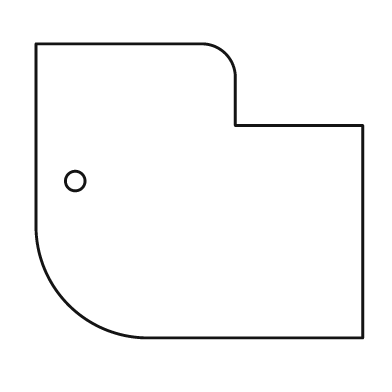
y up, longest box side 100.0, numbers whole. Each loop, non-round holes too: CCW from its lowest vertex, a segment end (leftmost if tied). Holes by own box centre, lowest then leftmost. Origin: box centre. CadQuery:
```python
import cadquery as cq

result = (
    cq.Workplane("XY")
    .moveTo(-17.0, -45.0)
    .lineTo(50.0, -45.0)
    .lineTo(50.0, 20.0)
    .lineTo(11.0, 20.0)
    .lineTo(11.0, 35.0)
    .threePointArc((8.0, 42.0), (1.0, 45.0))
    .lineTo(-50.0, 45.0)
    .lineTo(-50.0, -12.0)
    .threePointArc((-40.0, -35.0), (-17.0, -45.0))
    .close()
    .moveTo(-38.0, 3.0)
    .circle(3.0)
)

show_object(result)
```